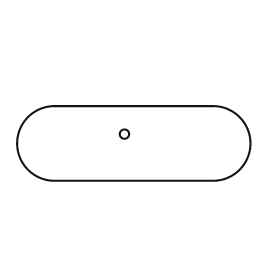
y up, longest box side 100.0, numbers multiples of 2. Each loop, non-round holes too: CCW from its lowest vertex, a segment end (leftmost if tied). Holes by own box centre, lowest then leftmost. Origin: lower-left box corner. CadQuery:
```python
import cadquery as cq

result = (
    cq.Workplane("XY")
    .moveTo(16.0, 0.0)
    .lineTo(84.0, 0.0)
    .threePointArc((100.0, 16.0), (84.0, 32.0))
    .lineTo(16.0, 32.0)
    .threePointArc((0.0, 16.0), (16.0, 0.0))
    .close()
    .moveTo(46.0, 20.0)
    .circle(2.0)
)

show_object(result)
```